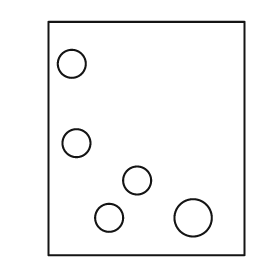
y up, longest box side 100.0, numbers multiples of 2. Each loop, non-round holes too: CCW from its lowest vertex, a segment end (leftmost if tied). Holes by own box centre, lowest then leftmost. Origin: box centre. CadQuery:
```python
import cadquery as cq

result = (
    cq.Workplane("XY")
    .moveTo(-42.0, -50.0)
    .lineTo(42.0, -50.0)
    .lineTo(42.0, 50.0)
    .lineTo(-42.0, 50.0)
    .close()
    .moveTo(-16.0, -34.0)
    .circle(6.0)
    .moveTo(20.0, -34.0)
    .circle(8.0)
    .moveTo(-4.0, -18.0)
    .circle(6.0)
    .moveTo(-30.0, -2.0)
    .circle(6.0)
    .moveTo(-32.0, 32.0)
    .circle(6.0)
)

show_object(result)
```